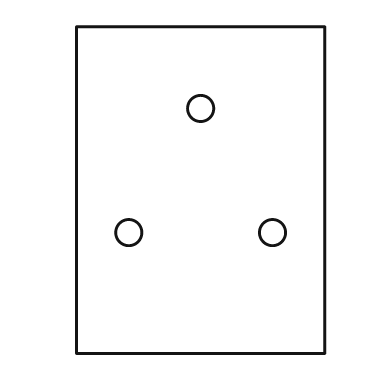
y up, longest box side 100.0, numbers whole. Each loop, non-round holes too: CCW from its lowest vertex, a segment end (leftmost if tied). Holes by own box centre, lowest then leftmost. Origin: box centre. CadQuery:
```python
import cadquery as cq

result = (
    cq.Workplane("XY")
    .moveTo(-38.0, -50.0)
    .lineTo(38.0, -50.0)
    .lineTo(38.0, 50.0)
    .lineTo(-38.0, 50.0)
    .close()
    .moveTo(-22.0, -13.0)
    .circle(4.0)
    .moveTo(22.0, -13.0)
    .circle(4.0)
    .moveTo(0.0, 25.0)
    .circle(4.0)
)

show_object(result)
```